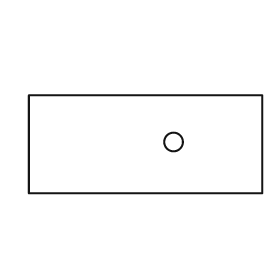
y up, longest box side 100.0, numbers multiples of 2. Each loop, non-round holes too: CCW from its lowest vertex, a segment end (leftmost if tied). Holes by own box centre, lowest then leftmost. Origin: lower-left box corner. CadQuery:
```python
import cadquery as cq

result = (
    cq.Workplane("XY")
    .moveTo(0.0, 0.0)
    .lineTo(100.0, 0.0)
    .lineTo(100.0, 42.0)
    .lineTo(0.0, 42.0)
    .close()
    .moveTo(62.0, 22.0)
    .circle(4.0)
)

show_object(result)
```